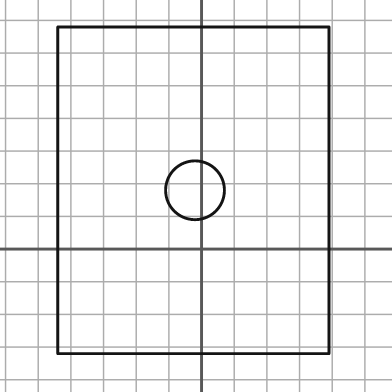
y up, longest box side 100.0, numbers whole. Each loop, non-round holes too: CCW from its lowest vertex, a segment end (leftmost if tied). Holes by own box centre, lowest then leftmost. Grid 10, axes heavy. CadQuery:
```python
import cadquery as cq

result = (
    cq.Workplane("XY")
    .moveTo(-44.0, -32.0)
    .lineTo(39.0, -32.0)
    .lineTo(39.0, 68.0)
    .lineTo(-44.0, 68.0)
    .close()
    .moveTo(-2.0, 18.0)
    .circle(9.0)
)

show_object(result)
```